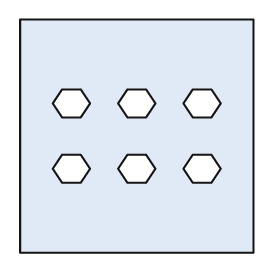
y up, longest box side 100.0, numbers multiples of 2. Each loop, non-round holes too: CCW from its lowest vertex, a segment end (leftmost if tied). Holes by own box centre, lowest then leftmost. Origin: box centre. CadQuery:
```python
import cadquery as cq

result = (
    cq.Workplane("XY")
    .moveTo(-50.0, -50.0)
    .lineTo(50.0, -50.0)
    .lineTo(50.0, 50.0)
    .lineTo(-50.0, 50.0)
    .close()
    .moveTo(-32.0, -20.0)
    .lineTo(-24.0, -20.0)
    .lineTo(-20.0, -14.0)
    .lineTo(-24.0, -8.0)
    .lineTo(-32.0, -8.0)
    .lineTo(-36.0, -14.0)
    .close()
    .moveTo(-4.0, -20.0)
    .lineTo(4.0, -20.0)
    .lineTo(8.0, -14.0)
    .lineTo(4.0, -8.0)
    .lineTo(-4.0, -8.0)
    .lineTo(-8.0, -14.0)
    .close()
    .moveTo(24.0, -20.0)
    .lineTo(32.0, -20.0)
    .lineTo(36.0, -14.0)
    .lineTo(32.0, -8.0)
    .lineTo(24.0, -8.0)
    .lineTo(20.0, -14.0)
    .close()
    .moveTo(-32.0, 8.0)
    .lineTo(-24.0, 8.0)
    .lineTo(-20.0, 14.0)
    .lineTo(-24.0, 20.0)
    .lineTo(-32.0, 20.0)
    .lineTo(-36.0, 14.0)
    .close()
    .moveTo(-4.0, 8.0)
    .lineTo(4.0, 8.0)
    .lineTo(8.0, 14.0)
    .lineTo(4.0, 20.0)
    .lineTo(-4.0, 20.0)
    .lineTo(-8.0, 14.0)
    .close()
    .moveTo(24.0, 8.0)
    .lineTo(32.0, 8.0)
    .lineTo(36.0, 14.0)
    .lineTo(32.0, 20.0)
    .lineTo(24.0, 20.0)
    .lineTo(20.0, 14.0)
    .close()
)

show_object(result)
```